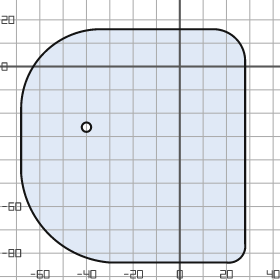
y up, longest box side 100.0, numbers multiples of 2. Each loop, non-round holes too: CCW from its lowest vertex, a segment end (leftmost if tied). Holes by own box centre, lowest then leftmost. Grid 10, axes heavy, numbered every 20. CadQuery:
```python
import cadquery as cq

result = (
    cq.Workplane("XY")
    .moveTo(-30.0, -84.0)
    .lineTo(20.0, -84.0)
    .threePointArc((26.0, -82.0), (28.0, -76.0))
    .lineTo(28.0, 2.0)
    .threePointArc((24.0, 12.0), (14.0, 16.0))
    .lineTo(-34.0, 16.0)
    .threePointArc((-58.0, 6.0), (-68.0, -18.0))
    .lineTo(-68.0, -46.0)
    .threePointArc((-56.0, -72.0), (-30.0, -84.0))
    .close()
    .moveTo(-40.0, -26.0)
    .circle(2.0)
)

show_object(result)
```